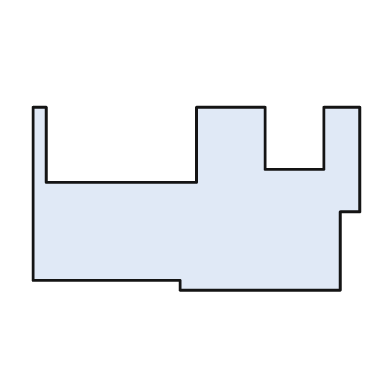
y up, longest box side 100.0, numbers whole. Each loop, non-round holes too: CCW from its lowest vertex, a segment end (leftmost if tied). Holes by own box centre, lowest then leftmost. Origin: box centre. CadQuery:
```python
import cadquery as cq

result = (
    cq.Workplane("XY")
    .moveTo(-5.0, -28.0)
    .lineTo(44.0, -28.0)
    .lineTo(44.0, -4.0)
    .lineTo(50.0, -4.0)
    .lineTo(50.0, 28.0)
    .lineTo(39.0, 28.0)
    .lineTo(39.0, 9.0)
    .lineTo(21.0, 9.0)
    .lineTo(21.0, 28.0)
    .lineTo(0.0, 28.0)
    .lineTo(0.0, 5.0)
    .lineTo(-46.0, 5.0)
    .lineTo(-46.0, 28.0)
    .lineTo(-50.0, 28.0)
    .lineTo(-50.0, -25.0)
    .lineTo(-5.0, -25.0)
    .close()
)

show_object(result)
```